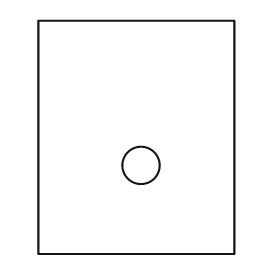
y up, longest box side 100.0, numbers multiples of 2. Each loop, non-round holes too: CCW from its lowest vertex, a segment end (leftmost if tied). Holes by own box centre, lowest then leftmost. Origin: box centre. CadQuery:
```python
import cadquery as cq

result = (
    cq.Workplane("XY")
    .moveTo(-42.0, -50.0)
    .lineTo(42.0, -50.0)
    .lineTo(42.0, 50.0)
    .lineTo(-42.0, 50.0)
    .close()
    .moveTo(2.0, -12.0)
    .circle(8.0)
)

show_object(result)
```